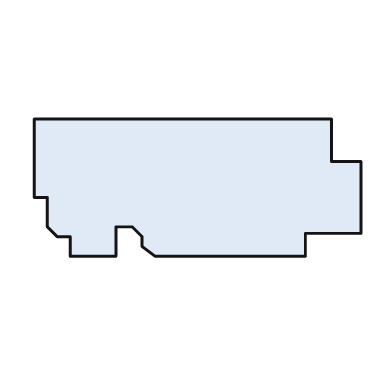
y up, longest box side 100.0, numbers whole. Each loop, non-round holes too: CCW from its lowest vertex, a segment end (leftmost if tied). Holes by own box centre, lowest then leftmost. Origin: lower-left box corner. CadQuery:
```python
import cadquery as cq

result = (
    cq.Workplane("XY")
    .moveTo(11.0, 0.0)
    .lineTo(25.0, 0.0)
    .lineTo(25.0, 9.0)
    .lineTo(30.0, 9.0)
    .lineTo(33.0, 6.0)
    .lineTo(33.0, 3.0)
    .lineTo(37.0, 0.0)
    .lineTo(83.0, 0.0)
    .lineTo(83.0, 7.0)
    .lineTo(100.0, 7.0)
    .lineTo(100.0, 29.0)
    .lineTo(91.0, 29.0)
    .lineTo(91.0, 42.0)
    .lineTo(0.0, 42.0)
    .lineTo(0.0, 18.0)
    .lineTo(4.0, 18.0)
    .lineTo(4.0, 9.0)
    .lineTo(7.0, 6.0)
    .lineTo(11.0, 6.0)
    .close()
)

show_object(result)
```